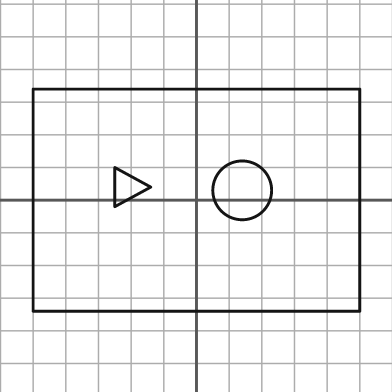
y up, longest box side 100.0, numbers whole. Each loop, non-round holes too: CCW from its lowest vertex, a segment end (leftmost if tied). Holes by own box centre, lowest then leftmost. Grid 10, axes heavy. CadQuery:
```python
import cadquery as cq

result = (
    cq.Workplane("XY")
    .moveTo(-50.0, -34.0)
    .lineTo(50.0, -34.0)
    .lineTo(50.0, 34.0)
    .lineTo(-50.0, 34.0)
    .close()
    .moveTo(14.0, 3.0)
    .circle(9.0)
    .moveTo(-25.0, -2.0)
    .lineTo(-14.0, 4.0)
    .lineTo(-25.0, 10.0)
    .close()
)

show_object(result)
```